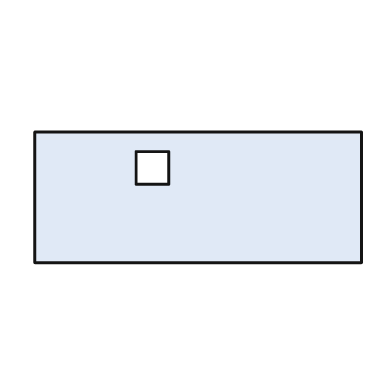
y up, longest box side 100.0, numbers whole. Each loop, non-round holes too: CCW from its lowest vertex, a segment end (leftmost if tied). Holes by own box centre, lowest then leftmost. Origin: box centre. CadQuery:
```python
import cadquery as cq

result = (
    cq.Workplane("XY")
    .moveTo(-50.0, -20.0)
    .lineTo(50.0, -20.0)
    .lineTo(50.0, 20.0)
    .lineTo(-50.0, 20.0)
    .close()
    .moveTo(-19.0, 4.0)
    .lineTo(-9.0, 4.0)
    .lineTo(-9.0, 14.0)
    .lineTo(-19.0, 14.0)
    .close()
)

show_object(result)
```